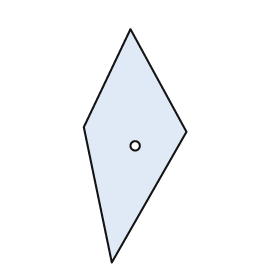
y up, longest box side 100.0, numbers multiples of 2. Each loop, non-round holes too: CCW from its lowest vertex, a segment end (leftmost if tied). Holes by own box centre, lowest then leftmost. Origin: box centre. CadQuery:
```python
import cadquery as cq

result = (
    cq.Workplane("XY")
    .moveTo(-10.0, -50.0)
    .lineTo(22.0, 6.0)
    .lineTo(-2.0, 50.0)
    .lineTo(-22.0, 8.0)
    .close()
    .moveTo(0.0, 0.0)
    .circle(2.0)
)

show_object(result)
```